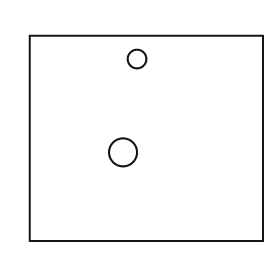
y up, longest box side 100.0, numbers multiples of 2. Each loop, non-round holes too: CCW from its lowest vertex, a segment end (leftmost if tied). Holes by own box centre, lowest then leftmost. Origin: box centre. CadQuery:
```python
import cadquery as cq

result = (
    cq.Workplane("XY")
    .moveTo(-50.0, -44.0)
    .lineTo(50.0, -44.0)
    .lineTo(50.0, 44.0)
    .lineTo(-50.0, 44.0)
    .close()
    .moveTo(-10.0, -6.0)
    .circle(6.0)
    .moveTo(-4.0, 34.0)
    .circle(4.0)
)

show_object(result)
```